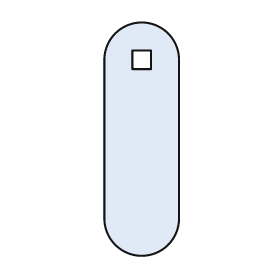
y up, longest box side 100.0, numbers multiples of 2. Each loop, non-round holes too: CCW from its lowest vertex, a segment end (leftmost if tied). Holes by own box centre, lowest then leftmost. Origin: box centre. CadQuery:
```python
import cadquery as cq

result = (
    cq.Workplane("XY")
    .moveTo(-16.0, -34.0)
    .threePointArc((0.0, -50.0), (16.0, -34.0))
    .lineTo(16.0, 34.0)
    .threePointArc((0.0, 50.0), (-16.0, 34.0))
    .close()
    .moveTo(-4.0, 30.0)
    .lineTo(4.0, 30.0)
    .lineTo(4.0, 38.0)
    .lineTo(-4.0, 38.0)
    .close()
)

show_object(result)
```